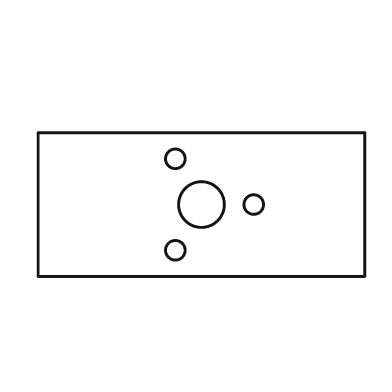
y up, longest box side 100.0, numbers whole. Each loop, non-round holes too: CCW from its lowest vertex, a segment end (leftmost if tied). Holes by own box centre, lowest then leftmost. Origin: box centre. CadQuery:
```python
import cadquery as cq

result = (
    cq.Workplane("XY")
    .moveTo(-50.0, -22.0)
    .lineTo(50.0, -22.0)
    .lineTo(50.0, 22.0)
    .lineTo(-50.0, 22.0)
    .close()
    .moveTo(-8.0, -14.0)
    .circle(3.0)
    .moveTo(0.0, 0.0)
    .circle(7.0)
    .moveTo(16.0, 0.0)
    .circle(3.0)
    .moveTo(-8.0, 14.0)
    .circle(3.0)
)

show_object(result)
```